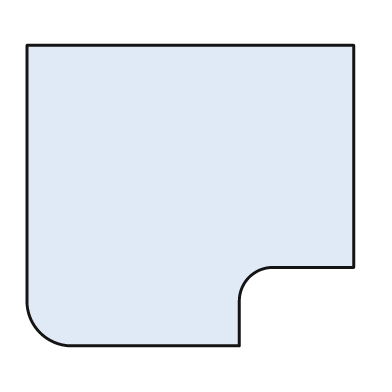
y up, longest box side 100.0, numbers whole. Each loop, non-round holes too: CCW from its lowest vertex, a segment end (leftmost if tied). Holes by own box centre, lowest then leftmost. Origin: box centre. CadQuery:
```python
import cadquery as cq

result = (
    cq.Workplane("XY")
    .moveTo(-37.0, -46.0)
    .lineTo(15.0, -46.0)
    .lineTo(15.0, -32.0)
    .threePointArc((18.0, -25.0), (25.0, -22.0))
    .lineTo(50.0, -22.0)
    .lineTo(50.0, 46.0)
    .lineTo(-50.0, 46.0)
    .lineTo(-50.0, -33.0)
    .threePointArc((-46.0, -42.0), (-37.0, -46.0))
    .close()
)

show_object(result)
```